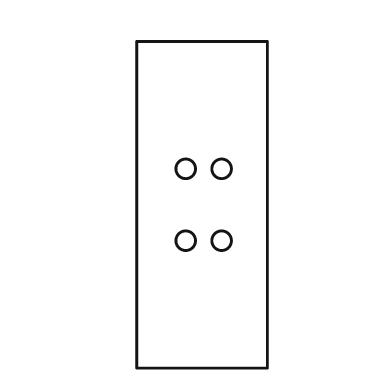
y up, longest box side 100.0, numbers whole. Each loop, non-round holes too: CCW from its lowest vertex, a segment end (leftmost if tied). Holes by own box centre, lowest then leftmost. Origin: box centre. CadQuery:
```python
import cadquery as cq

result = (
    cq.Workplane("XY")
    .moveTo(-20.0, -50.0)
    .lineTo(20.0, -50.0)
    .lineTo(20.0, 50.0)
    .lineTo(-20.0, 50.0)
    .close()
    .moveTo(-5.0, -11.0)
    .circle(3.0)
    .moveTo(6.0, -11.0)
    .circle(3.0)
    .moveTo(-5.0, 11.0)
    .circle(3.0)
    .moveTo(6.0, 11.0)
    .circle(3.0)
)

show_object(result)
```